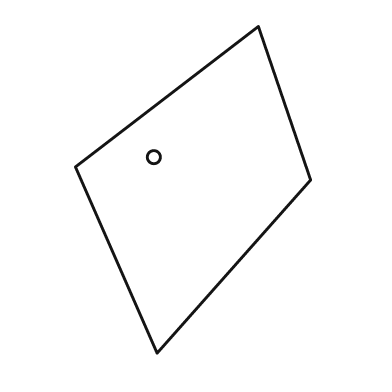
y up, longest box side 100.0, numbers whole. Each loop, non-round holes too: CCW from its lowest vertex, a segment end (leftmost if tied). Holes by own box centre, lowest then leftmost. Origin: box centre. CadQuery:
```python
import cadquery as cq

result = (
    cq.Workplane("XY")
    .moveTo(-11.0, -50.0)
    .lineTo(36.0, 3.0)
    .lineTo(20.0, 50.0)
    .lineTo(-36.0, 7.0)
    .close()
    .moveTo(-12.0, 10.0)
    .circle(2.0)
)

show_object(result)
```